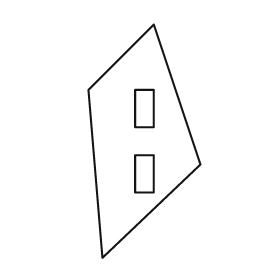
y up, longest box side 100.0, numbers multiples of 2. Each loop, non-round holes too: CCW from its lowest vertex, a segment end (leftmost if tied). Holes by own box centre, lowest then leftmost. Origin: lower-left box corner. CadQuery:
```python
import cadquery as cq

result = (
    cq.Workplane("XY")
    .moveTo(6.0, 0.0)
    .lineTo(48.0, 40.0)
    .lineTo(28.0, 100.0)
    .lineTo(0.0, 72.0)
    .close()
    .moveTo(20.0, 28.0)
    .lineTo(28.0, 28.0)
    .lineTo(28.0, 44.0)
    .lineTo(20.0, 44.0)
    .close()
    .moveTo(20.0, 56.0)
    .lineTo(28.0, 56.0)
    .lineTo(28.0, 72.0)
    .lineTo(20.0, 72.0)
    .close()
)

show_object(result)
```